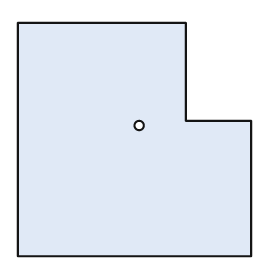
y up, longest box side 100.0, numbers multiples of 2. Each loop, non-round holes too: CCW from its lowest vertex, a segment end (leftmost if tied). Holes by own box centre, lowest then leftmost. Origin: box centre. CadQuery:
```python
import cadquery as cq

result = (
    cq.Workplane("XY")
    .moveTo(-50.0, -50.0)
    .lineTo(50.0, -50.0)
    .lineTo(50.0, 8.0)
    .lineTo(22.0, 8.0)
    .lineTo(22.0, 50.0)
    .lineTo(-50.0, 50.0)
    .close()
    .moveTo(2.0, 6.0)
    .circle(2.0)
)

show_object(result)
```